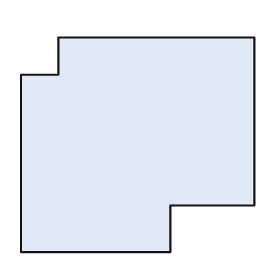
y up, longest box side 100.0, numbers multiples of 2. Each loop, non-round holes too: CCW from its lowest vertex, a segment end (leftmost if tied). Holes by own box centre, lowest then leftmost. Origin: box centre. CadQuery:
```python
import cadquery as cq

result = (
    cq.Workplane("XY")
    .moveTo(-50.0, -46.0)
    .lineTo(14.0, -46.0)
    .lineTo(14.0, -26.0)
    .lineTo(50.0, -26.0)
    .lineTo(50.0, 46.0)
    .lineTo(-34.0, 46.0)
    .lineTo(-34.0, 30.0)
    .lineTo(-50.0, 30.0)
    .close()
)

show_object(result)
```